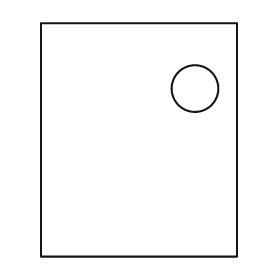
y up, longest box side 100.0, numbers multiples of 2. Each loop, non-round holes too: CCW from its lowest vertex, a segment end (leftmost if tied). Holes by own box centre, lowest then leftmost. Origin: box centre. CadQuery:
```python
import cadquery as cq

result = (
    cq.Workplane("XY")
    .moveTo(-42.0, -50.0)
    .lineTo(42.0, -50.0)
    .lineTo(42.0, 50.0)
    .lineTo(-42.0, 50.0)
    .close()
    .moveTo(24.0, 22.0)
    .circle(10.0)
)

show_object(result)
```